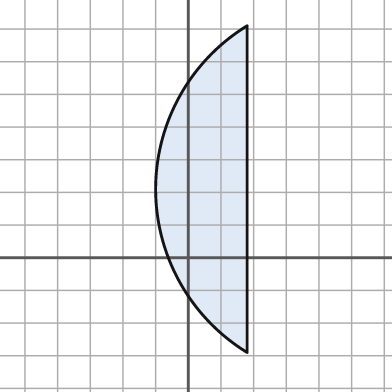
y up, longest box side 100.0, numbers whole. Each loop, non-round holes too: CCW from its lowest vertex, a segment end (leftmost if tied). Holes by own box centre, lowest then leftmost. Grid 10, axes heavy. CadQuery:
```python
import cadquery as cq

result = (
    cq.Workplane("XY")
    .moveTo(18.0, -29.0)
    .lineTo(18.0, 71.0)
    .threePointArc((-10.0, 21.0), (18.0, -29.0))
    .close()
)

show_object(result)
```